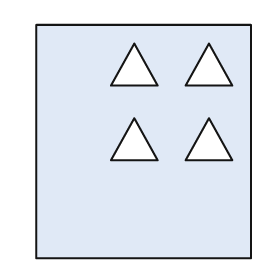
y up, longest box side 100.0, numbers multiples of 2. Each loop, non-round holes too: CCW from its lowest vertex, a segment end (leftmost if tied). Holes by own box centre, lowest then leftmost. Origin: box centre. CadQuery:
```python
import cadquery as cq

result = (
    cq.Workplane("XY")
    .moveTo(-46.0, -50.0)
    .lineTo(46.0, -50.0)
    .lineTo(46.0, 50.0)
    .lineTo(-46.0, 50.0)
    .close()
    .moveTo(-14.0, -8.0)
    .lineTo(6.0, -8.0)
    .lineTo(-4.0, 10.0)
    .close()
    .moveTo(18.0, -8.0)
    .lineTo(38.0, -8.0)
    .lineTo(28.0, 10.0)
    .close()
    .moveTo(-14.0, 24.0)
    .lineTo(6.0, 24.0)
    .lineTo(-4.0, 42.0)
    .close()
    .moveTo(18.0, 24.0)
    .lineTo(38.0, 24.0)
    .lineTo(28.0, 42.0)
    .close()
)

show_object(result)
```